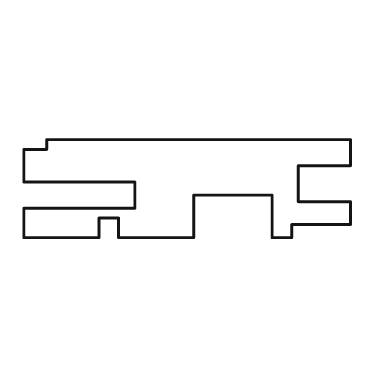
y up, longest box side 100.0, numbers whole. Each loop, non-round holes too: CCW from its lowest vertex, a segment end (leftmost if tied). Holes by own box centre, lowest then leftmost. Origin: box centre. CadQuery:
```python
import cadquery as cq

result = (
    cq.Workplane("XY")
    .moveTo(-50.0, -15.0)
    .lineTo(-27.0, -15.0)
    .lineTo(-27.0, -9.0)
    .lineTo(-21.0, -9.0)
    .lineTo(-21.0, -15.0)
    .lineTo(2.0, -15.0)
    .lineTo(2.0, -2.0)
    .lineTo(26.0, -2.0)
    .lineTo(26.0, -15.0)
    .lineTo(32.0, -15.0)
    .lineTo(32.0, -11.0)
    .lineTo(50.0, -11.0)
    .lineTo(50.0, -4.0)
    .lineTo(34.0, -4.0)
    .lineTo(34.0, 7.0)
    .lineTo(50.0, 7.0)
    .lineTo(50.0, 15.0)
    .lineTo(-43.0, 15.0)
    .lineTo(-43.0, 12.0)
    .lineTo(-50.0, 12.0)
    .lineTo(-50.0, 2.0)
    .lineTo(-16.0, 2.0)
    .lineTo(-16.0, -6.0)
    .lineTo(-50.0, -6.0)
    .close()
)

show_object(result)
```